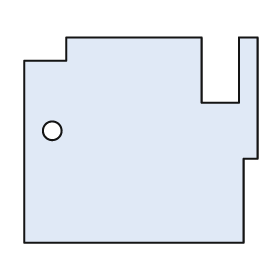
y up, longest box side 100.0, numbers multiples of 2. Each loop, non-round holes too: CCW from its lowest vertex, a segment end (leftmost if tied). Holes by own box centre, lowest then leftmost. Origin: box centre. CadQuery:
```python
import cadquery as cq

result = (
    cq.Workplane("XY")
    .moveTo(-50.0, -44.0)
    .lineTo(44.0, -44.0)
    .lineTo(44.0, -8.0)
    .lineTo(50.0, -8.0)
    .lineTo(50.0, 44.0)
    .lineTo(42.0, 44.0)
    .lineTo(42.0, 16.0)
    .lineTo(26.0, 16.0)
    .lineTo(26.0, 44.0)
    .lineTo(-32.0, 44.0)
    .lineTo(-32.0, 34.0)
    .lineTo(-50.0, 34.0)
    .close()
    .moveTo(-38.0, 4.0)
    .circle(4.0)
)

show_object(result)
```